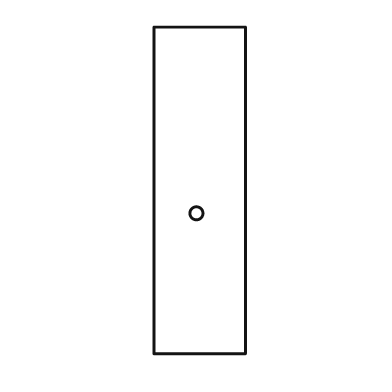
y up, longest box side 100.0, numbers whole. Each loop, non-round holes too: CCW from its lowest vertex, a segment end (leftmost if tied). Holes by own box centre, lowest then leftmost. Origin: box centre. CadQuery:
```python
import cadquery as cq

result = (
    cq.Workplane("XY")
    .moveTo(-14.0, -50.0)
    .lineTo(14.0, -50.0)
    .lineTo(14.0, 50.0)
    .lineTo(-14.0, 50.0)
    .close()
    .moveTo(-1.0, -7.0)
    .circle(2.0)
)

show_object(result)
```